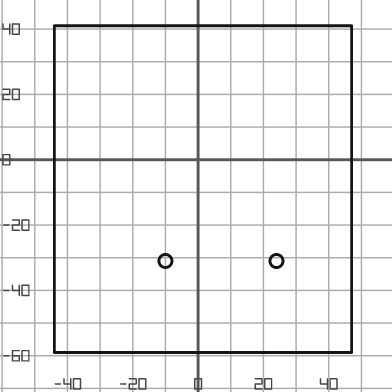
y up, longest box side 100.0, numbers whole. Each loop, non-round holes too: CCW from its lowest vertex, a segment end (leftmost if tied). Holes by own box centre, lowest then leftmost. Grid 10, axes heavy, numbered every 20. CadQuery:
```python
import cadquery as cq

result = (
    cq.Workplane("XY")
    .moveTo(-44.0, -59.0)
    .lineTo(47.0, -59.0)
    .lineTo(47.0, 41.0)
    .lineTo(-44.0, 41.0)
    .close()
    .moveTo(-10.0, -31.0)
    .circle(2.0)
    .moveTo(24.0, -31.0)
    .circle(2.0)
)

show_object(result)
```